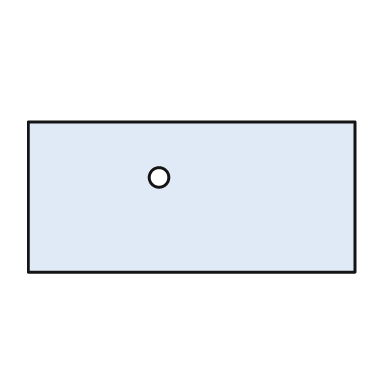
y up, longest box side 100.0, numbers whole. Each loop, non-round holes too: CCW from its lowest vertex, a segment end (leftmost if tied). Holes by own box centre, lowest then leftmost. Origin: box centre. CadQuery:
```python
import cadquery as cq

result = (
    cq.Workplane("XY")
    .moveTo(-50.0, -23.0)
    .lineTo(50.0, -23.0)
    .lineTo(50.0, 23.0)
    .lineTo(-50.0, 23.0)
    .close()
    .moveTo(-10.0, 6.0)
    .circle(3.0)
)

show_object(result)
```